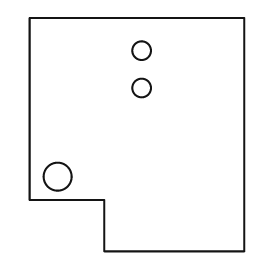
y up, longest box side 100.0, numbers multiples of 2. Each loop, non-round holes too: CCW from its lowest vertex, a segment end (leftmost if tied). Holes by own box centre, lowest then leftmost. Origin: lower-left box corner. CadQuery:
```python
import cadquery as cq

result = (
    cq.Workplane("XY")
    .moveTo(32.0, 0.0)
    .lineTo(92.0, 0.0)
    .lineTo(92.0, 100.0)
    .lineTo(0.0, 100.0)
    .lineTo(0.0, 22.0)
    .lineTo(32.0, 22.0)
    .close()
    .moveTo(12.0, 32.0)
    .circle(6.0)
    .moveTo(48.0, 70.0)
    .circle(4.0)
    .moveTo(48.0, 86.0)
    .circle(4.0)
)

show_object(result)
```